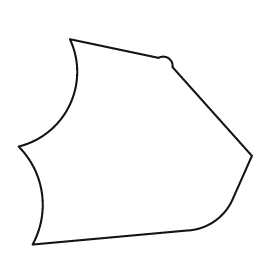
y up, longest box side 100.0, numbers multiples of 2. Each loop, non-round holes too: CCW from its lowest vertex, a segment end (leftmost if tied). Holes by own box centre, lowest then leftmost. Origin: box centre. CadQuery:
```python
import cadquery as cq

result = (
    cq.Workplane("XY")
    .moveTo(-44.0, -44.0)
    .lineTo(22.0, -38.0)
    .threePointArc((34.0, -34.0), (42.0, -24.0))
    .lineTo(50.0, -6.0)
    .lineTo(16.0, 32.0)
    .threePointArc((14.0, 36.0), (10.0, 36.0))
    .lineTo(-28.0, 44.0)
    .threePointArc((-28.0, 16.0), (-50.0, -2.0))
    .threePointArc((-40.0, -22.0), (-44.0, -44.0))
    .close()
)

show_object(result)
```